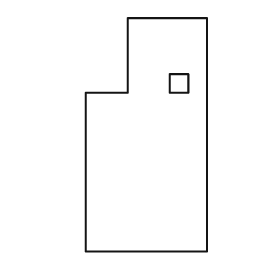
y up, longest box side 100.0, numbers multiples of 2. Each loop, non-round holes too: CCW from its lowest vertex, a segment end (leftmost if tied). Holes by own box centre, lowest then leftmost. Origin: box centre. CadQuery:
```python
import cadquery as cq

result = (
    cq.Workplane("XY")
    .moveTo(-26.0, -50.0)
    .lineTo(26.0, -50.0)
    .lineTo(26.0, 50.0)
    .lineTo(-8.0, 50.0)
    .lineTo(-8.0, 18.0)
    .lineTo(-26.0, 18.0)
    .close()
    .moveTo(10.0, 18.0)
    .lineTo(18.0, 18.0)
    .lineTo(18.0, 26.0)
    .lineTo(10.0, 26.0)
    .close()
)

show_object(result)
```